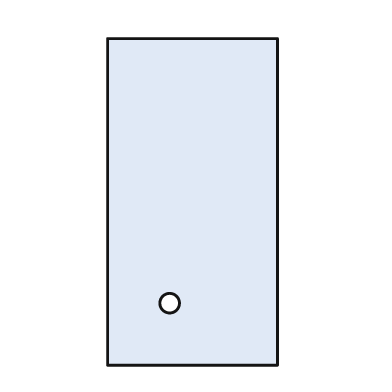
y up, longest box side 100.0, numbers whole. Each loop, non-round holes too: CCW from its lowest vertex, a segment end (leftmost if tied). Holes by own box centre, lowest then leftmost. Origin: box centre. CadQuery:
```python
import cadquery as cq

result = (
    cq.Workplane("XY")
    .moveTo(-26.0, -50.0)
    .lineTo(26.0, -50.0)
    .lineTo(26.0, 50.0)
    .lineTo(-26.0, 50.0)
    .close()
    .moveTo(-7.0, -31.0)
    .circle(3.0)
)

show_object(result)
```